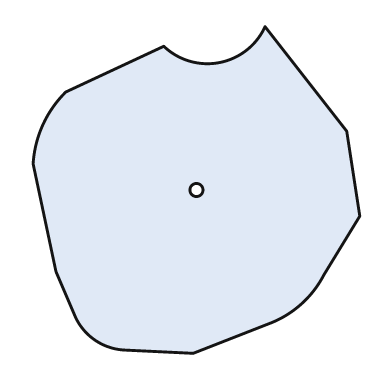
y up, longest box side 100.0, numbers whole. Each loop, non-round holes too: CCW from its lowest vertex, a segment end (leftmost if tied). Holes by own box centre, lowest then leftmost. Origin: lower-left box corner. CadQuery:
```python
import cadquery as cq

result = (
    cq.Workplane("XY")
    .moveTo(49.0, 0.0)
    .lineTo(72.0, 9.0)
    .threePointArc((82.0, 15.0), (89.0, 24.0))
    .lineTo(100.0, 42.0)
    .lineTo(96.0, 68.0)
    .lineTo(71.0, 100.0)
    .threePointArc((57.0, 89.0), (40.0, 94.0))
    .lineTo(10.0, 80.0)
    .threePointArc((3.0, 70.0), (0.0, 58.0))
    .lineTo(7.0, 25.0)
    .lineTo(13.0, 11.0)
    .threePointArc((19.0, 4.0), (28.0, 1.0))
    .close()
    .moveTo(50.0, 50.0)
    .circle(2.0)
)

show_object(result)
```